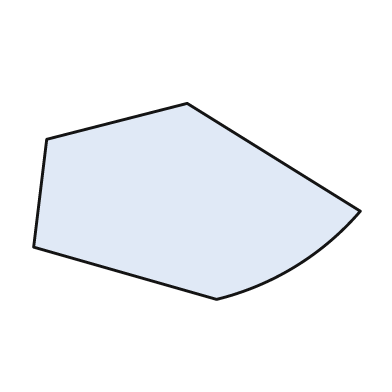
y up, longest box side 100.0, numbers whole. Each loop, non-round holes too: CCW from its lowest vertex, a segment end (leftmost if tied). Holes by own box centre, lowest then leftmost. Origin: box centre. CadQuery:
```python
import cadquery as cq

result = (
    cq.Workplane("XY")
    .moveTo(6.0, -30.0)
    .threePointArc((30.0, -20.0), (50.0, -3.0))
    .lineTo(-3.0, 30.0)
    .lineTo(-46.0, 19.0)
    .lineTo(-50.0, -14.0)
    .close()
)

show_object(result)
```